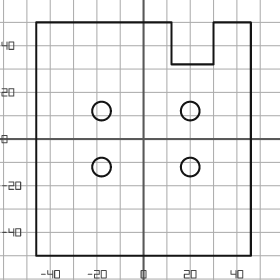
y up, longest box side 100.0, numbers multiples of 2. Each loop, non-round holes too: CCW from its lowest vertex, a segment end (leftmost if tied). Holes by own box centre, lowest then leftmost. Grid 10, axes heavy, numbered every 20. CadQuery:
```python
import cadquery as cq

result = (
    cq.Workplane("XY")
    .moveTo(-46.0, -50.0)
    .lineTo(46.0, -50.0)
    .lineTo(46.0, 50.0)
    .lineTo(30.0, 50.0)
    .lineTo(30.0, 32.0)
    .lineTo(12.0, 32.0)
    .lineTo(12.0, 50.0)
    .lineTo(-46.0, 50.0)
    .close()
    .moveTo(-18.0, -12.0)
    .circle(4.0)
    .moveTo(20.0, -12.0)
    .circle(4.0)
    .moveTo(-18.0, 12.0)
    .circle(4.0)
    .moveTo(20.0, 12.0)
    .circle(4.0)
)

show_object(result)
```